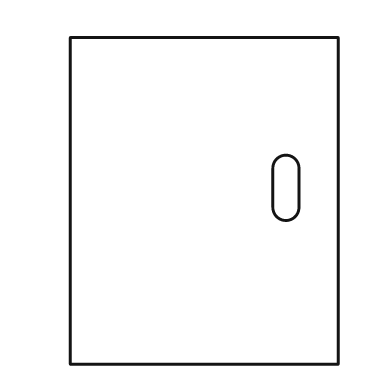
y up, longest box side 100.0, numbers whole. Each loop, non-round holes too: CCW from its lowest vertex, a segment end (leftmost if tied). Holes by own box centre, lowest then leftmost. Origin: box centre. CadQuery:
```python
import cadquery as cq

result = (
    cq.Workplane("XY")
    .moveTo(-41.0, -50.0)
    .lineTo(41.0, -50.0)
    .lineTo(41.0, 50.0)
    .lineTo(-41.0, 50.0)
    .close()
    .moveTo(21.0, -2.0)
    .threePointArc((25.0, -6.0), (29.0, -2.0))
    .lineTo(29.0, 10.0)
    .threePointArc((25.0, 14.0), (21.0, 10.0))
    .close()
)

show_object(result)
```